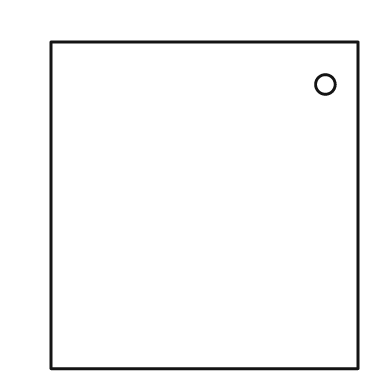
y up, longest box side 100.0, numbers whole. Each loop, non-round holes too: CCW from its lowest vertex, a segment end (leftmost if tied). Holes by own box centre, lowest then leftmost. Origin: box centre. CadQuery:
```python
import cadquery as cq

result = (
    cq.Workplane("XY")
    .moveTo(-47.0, -50.0)
    .lineTo(47.0, -50.0)
    .lineTo(47.0, 50.0)
    .lineTo(-47.0, 50.0)
    .close()
    .moveTo(37.0, 37.0)
    .circle(3.0)
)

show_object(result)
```